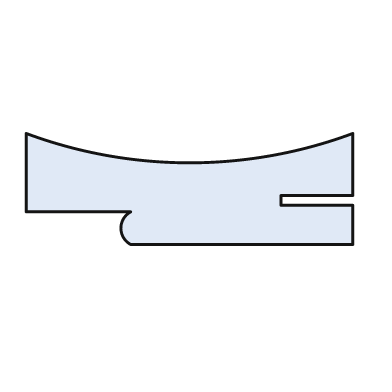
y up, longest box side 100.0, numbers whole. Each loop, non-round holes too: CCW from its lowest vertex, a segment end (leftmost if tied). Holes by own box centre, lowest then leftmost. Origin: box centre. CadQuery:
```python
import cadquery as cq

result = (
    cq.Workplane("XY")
    .moveTo(-18.0, -17.0)
    .lineTo(50.0, -17.0)
    .lineTo(50.0, -5.0)
    .lineTo(28.0, -5.0)
    .lineTo(28.0, -2.0)
    .lineTo(50.0, -2.0)
    .lineTo(50.0, 17.0)
    .threePointArc((0.0, 8.0), (-50.0, 17.0))
    .lineTo(-50.0, -7.0)
    .lineTo(-18.0, -7.0)
    .threePointArc((-21.0, -12.0), (-18.0, -17.0))
    .close()
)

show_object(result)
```